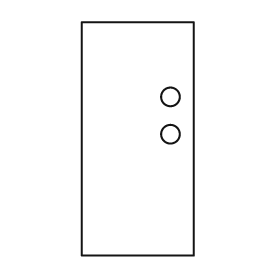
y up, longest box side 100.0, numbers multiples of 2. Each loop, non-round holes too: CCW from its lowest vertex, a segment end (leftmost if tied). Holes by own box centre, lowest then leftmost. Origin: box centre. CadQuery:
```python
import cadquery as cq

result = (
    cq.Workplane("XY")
    .moveTo(-24.0, -50.0)
    .lineTo(24.0, -50.0)
    .lineTo(24.0, 50.0)
    .lineTo(-24.0, 50.0)
    .close()
    .moveTo(14.0, 2.0)
    .circle(4.0)
    .moveTo(14.0, 18.0)
    .circle(4.0)
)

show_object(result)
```